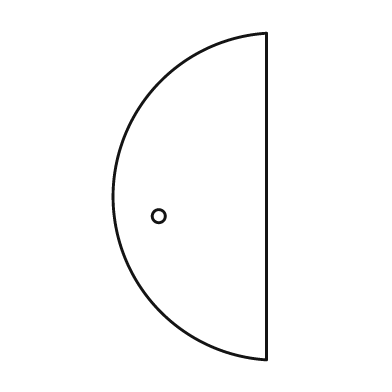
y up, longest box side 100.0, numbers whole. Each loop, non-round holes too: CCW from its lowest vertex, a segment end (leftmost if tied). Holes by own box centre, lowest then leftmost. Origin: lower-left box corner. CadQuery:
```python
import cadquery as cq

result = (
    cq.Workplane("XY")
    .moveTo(47.0, 0.0)
    .lineTo(47.0, 100.0)
    .threePointArc((0.0, 50.0), (47.0, 0.0))
    .close()
    .moveTo(14.0, 44.0)
    .circle(2.0)
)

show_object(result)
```